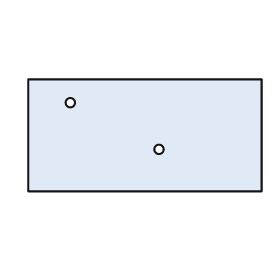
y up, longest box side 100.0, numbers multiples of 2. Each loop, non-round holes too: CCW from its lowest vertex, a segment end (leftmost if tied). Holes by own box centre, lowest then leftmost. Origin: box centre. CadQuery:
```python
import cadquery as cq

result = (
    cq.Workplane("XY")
    .moveTo(-50.0, -24.0)
    .lineTo(50.0, -24.0)
    .lineTo(50.0, 24.0)
    .lineTo(-50.0, 24.0)
    .close()
    .moveTo(6.0, -6.0)
    .circle(2.0)
    .moveTo(-32.0, 14.0)
    .circle(2.0)
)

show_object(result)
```